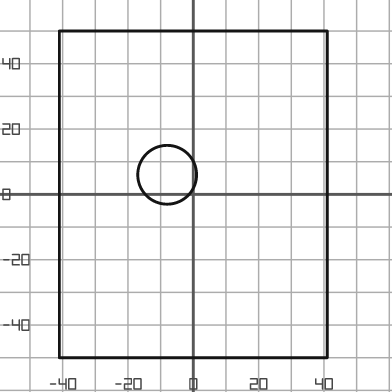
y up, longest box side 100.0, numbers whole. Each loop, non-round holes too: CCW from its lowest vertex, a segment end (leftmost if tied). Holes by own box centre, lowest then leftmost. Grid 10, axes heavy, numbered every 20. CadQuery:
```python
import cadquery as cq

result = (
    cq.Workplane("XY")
    .moveTo(-41.0, -50.0)
    .lineTo(41.0, -50.0)
    .lineTo(41.0, 50.0)
    .lineTo(-41.0, 50.0)
    .close()
    .moveTo(-8.0, 6.0)
    .circle(9.0)
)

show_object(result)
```